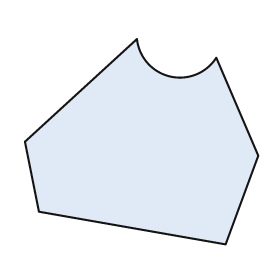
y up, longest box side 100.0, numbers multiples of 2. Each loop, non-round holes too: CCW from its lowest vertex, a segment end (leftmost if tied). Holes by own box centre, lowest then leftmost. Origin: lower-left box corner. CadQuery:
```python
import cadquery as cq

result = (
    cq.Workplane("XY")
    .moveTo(86.0, 0.0)
    .lineTo(100.0, 38.0)
    .lineTo(82.0, 80.0)
    .threePointArc((62.0, 72.0), (48.0, 88.0))
    .lineTo(0.0, 44.0)
    .lineTo(6.0, 14.0)
    .close()
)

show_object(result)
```